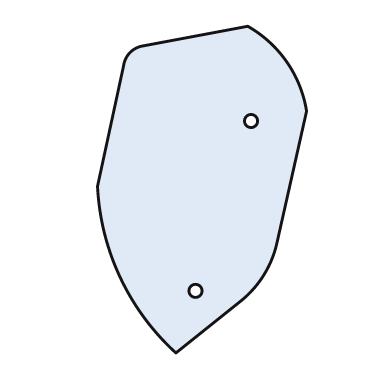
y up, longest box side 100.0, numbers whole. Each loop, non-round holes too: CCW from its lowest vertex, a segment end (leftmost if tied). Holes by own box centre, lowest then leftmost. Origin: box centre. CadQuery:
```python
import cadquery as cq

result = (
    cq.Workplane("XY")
    .moveTo(-8.0, -50.0)
    .lineTo(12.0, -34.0)
    .threePointArc((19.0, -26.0), (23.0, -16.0))
    .lineTo(32.0, 24.0)
    .threePointArc((26.0, 39.0), (14.0, 50.0))
    .lineTo(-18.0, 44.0)
    .threePointArc((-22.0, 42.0), (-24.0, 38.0))
    .lineTo(-32.0, 1.0)
    .threePointArc((-25.0, -27.0), (-8.0, -50.0))
    .close()
    .moveTo(-2.0, -31.0)
    .circle(2.0)
    .moveTo(15.0, 21.0)
    .circle(2.0)
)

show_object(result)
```